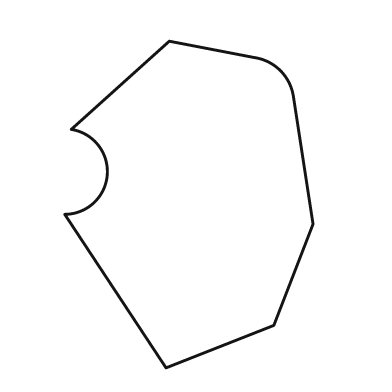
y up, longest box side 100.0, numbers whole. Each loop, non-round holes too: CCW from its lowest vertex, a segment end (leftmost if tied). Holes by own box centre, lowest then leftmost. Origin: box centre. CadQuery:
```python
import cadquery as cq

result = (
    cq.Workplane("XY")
    .moveTo(-7.0, -50.0)
    .lineTo(26.0, -37.0)
    .lineTo(38.0, -6.0)
    .lineTo(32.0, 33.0)
    .threePointArc((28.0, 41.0), (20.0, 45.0))
    .lineTo(-6.0, 50.0)
    .lineTo(-36.0, 23.0)
    .threePointArc((-25.0, 9.0), (-38.0, -3.0))
    .close()
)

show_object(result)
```